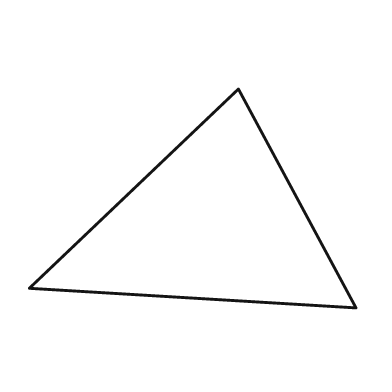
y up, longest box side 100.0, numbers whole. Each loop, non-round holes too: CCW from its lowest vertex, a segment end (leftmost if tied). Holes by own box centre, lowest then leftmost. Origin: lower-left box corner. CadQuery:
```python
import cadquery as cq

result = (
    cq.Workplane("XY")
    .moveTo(100.0, 0.0)
    .lineTo(64.0, 67.0)
    .lineTo(0.0, 6.0)
    .close()
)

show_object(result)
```